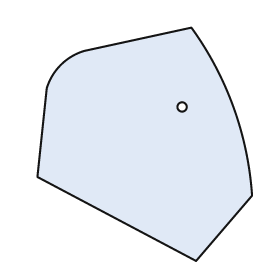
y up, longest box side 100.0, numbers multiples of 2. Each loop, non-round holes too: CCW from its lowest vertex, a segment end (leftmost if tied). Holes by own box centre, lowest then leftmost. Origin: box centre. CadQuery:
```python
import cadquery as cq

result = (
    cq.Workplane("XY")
    .moveTo(22.0, -50.0)
    .lineTo(46.0, -22.0)
    .threePointArc((38.0, 16.0), (20.0, 50.0))
    .lineTo(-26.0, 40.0)
    .threePointArc((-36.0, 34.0), (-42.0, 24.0))
    .lineTo(-46.0, -14.0)
    .close()
    .moveTo(16.0, 16.0)
    .circle(2.0)
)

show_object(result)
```